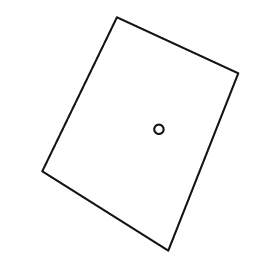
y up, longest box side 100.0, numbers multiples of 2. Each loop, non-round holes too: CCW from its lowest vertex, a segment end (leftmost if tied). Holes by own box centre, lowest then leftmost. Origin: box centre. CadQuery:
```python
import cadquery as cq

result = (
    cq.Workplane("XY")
    .moveTo(12.0, -50.0)
    .lineTo(42.0, 26.0)
    .lineTo(-10.0, 50.0)
    .lineTo(-42.0, -16.0)
    .close()
    .moveTo(8.0, 2.0)
    .circle(2.0)
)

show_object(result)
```